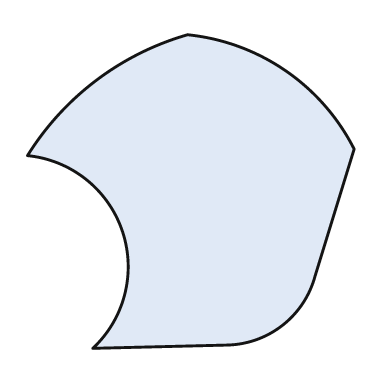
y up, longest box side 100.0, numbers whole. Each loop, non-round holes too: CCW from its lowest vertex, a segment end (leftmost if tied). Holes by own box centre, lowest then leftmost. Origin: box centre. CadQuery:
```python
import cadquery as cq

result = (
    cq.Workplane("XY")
    .moveTo(-30.0, -48.0)
    .lineTo(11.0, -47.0)
    .threePointArc((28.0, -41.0), (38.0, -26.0))
    .lineTo(50.0, 13.0)
    .threePointArc((29.0, 37.0), (-1.0, 48.0))
    .threePointArc((-29.0, 34.0), (-50.0, 11.0))
    .threePointArc((-21.0, -12.0), (-30.0, -48.0))
    .close()
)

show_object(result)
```